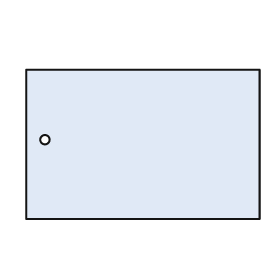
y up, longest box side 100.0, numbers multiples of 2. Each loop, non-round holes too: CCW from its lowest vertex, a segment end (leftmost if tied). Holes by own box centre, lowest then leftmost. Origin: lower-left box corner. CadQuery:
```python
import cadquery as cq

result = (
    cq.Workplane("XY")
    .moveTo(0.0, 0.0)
    .lineTo(100.0, 0.0)
    .lineTo(100.0, 64.0)
    .lineTo(0.0, 64.0)
    .close()
    .moveTo(8.0, 34.0)
    .circle(2.0)
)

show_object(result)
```